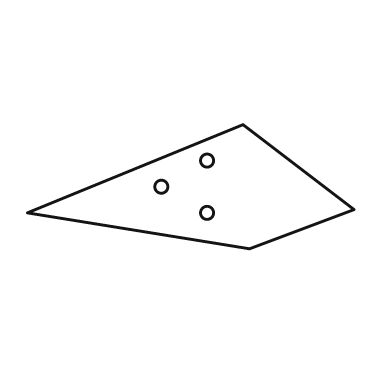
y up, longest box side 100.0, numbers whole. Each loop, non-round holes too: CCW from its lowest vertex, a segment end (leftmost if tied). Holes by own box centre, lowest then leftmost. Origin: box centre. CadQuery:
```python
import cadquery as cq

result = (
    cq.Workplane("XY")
    .moveTo(18.0, -19.0)
    .lineTo(50.0, -7.0)
    .lineTo(16.0, 19.0)
    .lineTo(-50.0, -8.0)
    .close()
    .moveTo(5.0, -8.0)
    .circle(2.0)
    .moveTo(-9.0, 0.0)
    .circle(2.0)
    .moveTo(5.0, 8.0)
    .circle(2.0)
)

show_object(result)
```